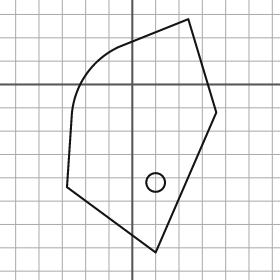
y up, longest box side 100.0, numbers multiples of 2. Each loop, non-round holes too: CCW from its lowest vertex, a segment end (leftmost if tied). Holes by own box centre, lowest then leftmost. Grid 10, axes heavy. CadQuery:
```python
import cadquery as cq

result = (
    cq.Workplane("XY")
    .moveTo(10.0, -72.0)
    .lineTo(36.0, -12.0)
    .lineTo(24.0, 28.0)
    .lineTo(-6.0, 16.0)
    .threePointArc((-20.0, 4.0), (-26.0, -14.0))
    .lineTo(-28.0, -44.0)
    .close()
    .moveTo(10.0, -42.0)
    .circle(4.0)
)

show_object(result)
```